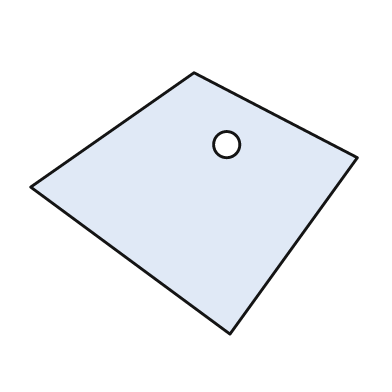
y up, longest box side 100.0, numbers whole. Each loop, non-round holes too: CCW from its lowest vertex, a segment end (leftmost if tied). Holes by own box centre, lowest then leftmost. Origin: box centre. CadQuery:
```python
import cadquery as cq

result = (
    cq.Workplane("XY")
    .moveTo(11.0, -40.0)
    .lineTo(50.0, 14.0)
    .lineTo(0.0, 40.0)
    .lineTo(-50.0, 5.0)
    .close()
    .moveTo(10.0, 18.0)
    .circle(4.0)
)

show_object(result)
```